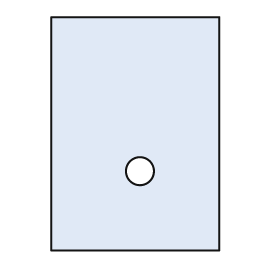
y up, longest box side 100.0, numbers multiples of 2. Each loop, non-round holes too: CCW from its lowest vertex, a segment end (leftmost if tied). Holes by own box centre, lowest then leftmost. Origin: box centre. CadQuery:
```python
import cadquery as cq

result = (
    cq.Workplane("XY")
    .moveTo(-36.0, -50.0)
    .lineTo(36.0, -50.0)
    .lineTo(36.0, 50.0)
    .lineTo(-36.0, 50.0)
    .close()
    .moveTo(2.0, -16.0)
    .circle(6.0)
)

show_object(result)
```